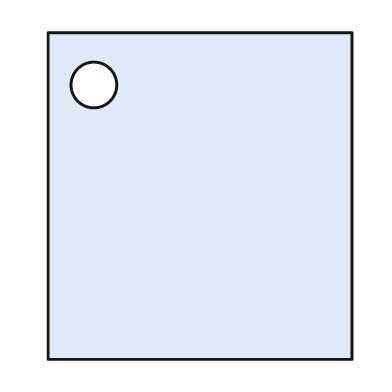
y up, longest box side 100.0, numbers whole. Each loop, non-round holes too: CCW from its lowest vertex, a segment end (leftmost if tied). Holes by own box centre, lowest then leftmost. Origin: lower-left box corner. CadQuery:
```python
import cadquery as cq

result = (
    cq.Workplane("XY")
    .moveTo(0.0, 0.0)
    .lineTo(93.0, 0.0)
    .lineTo(93.0, 100.0)
    .lineTo(0.0, 100.0)
    .close()
    .moveTo(14.0, 84.0)
    .circle(7.0)
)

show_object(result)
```